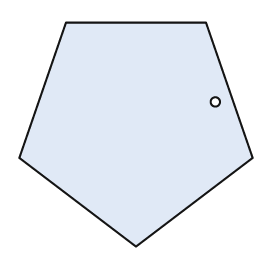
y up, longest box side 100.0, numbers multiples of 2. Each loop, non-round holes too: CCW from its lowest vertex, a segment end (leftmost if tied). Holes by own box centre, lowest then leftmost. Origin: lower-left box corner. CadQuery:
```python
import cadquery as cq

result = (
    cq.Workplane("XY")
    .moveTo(50.0, 0.0)
    .lineTo(100.0, 38.0)
    .lineTo(80.0, 96.0)
    .lineTo(20.0, 96.0)
    .lineTo(0.0, 38.0)
    .close()
    .moveTo(84.0, 62.0)
    .circle(2.0)
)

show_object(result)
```